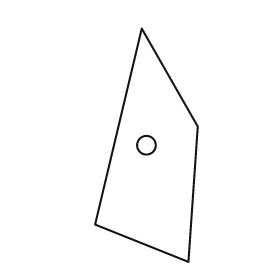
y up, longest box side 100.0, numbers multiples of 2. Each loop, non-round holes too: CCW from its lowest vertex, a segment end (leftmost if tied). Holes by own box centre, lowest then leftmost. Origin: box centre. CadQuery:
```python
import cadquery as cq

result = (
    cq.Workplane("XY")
    .moveTo(18.0, -50.0)
    .lineTo(22.0, 8.0)
    .lineTo(-2.0, 50.0)
    .lineTo(-22.0, -34.0)
    .close()
    .moveTo(0.0, 0.0)
    .circle(4.0)
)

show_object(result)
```